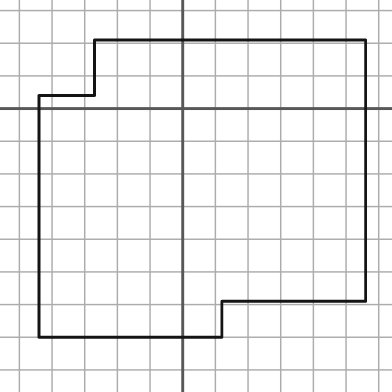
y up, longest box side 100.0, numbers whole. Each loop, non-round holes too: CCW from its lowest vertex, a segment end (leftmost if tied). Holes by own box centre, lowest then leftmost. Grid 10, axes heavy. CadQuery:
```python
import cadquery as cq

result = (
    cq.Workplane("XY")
    .moveTo(-44.0, -70.0)
    .lineTo(12.0, -70.0)
    .lineTo(12.0, -59.0)
    .lineTo(56.0, -59.0)
    .lineTo(56.0, 21.0)
    .lineTo(-27.0, 21.0)
    .lineTo(-27.0, 4.0)
    .lineTo(-44.0, 4.0)
    .close()
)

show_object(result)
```